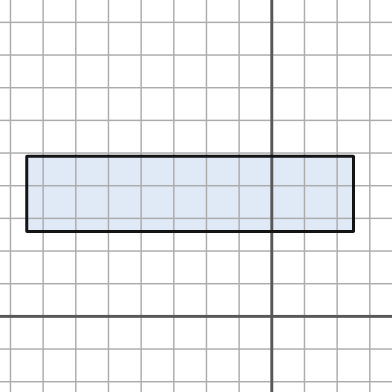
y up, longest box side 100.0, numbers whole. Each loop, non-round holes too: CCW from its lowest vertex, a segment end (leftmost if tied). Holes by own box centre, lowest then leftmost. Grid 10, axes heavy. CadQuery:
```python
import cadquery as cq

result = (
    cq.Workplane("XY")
    .moveTo(-75.0, 26.0)
    .lineTo(25.0, 26.0)
    .lineTo(25.0, 49.0)
    .lineTo(-75.0, 49.0)
    .close()
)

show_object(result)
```